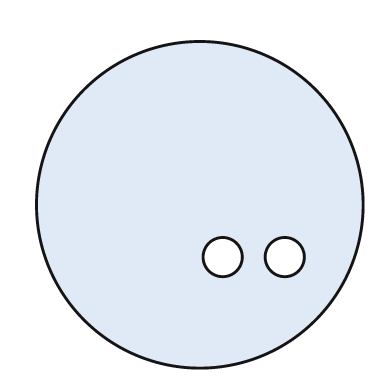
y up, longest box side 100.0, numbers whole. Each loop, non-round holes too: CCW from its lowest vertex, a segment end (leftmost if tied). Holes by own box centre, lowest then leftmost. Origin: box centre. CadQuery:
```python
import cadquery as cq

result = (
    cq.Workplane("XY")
    .moveTo(0.0, 0.0)
    .circle(50.0)
    .moveTo(7.0, -16.0)
    .circle(6.0)
    .moveTo(26.0, -16.0)
    .circle(6.0)
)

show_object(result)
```